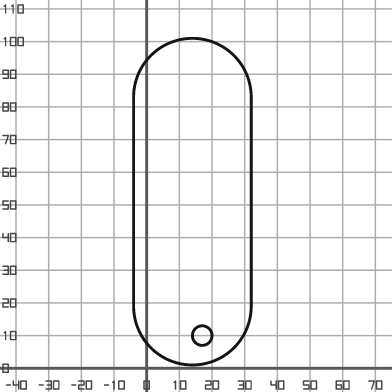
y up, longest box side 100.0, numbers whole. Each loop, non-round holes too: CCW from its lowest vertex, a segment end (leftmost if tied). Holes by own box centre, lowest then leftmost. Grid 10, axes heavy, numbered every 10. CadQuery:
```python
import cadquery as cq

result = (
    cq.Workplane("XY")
    .moveTo(-4.0, 19.0)
    .threePointArc((14.0, 1.0), (32.0, 19.0))
    .lineTo(32.0, 83.0)
    .threePointArc((14.0, 101.0), (-4.0, 83.0))
    .close()
    .moveTo(17.0, 10.0)
    .circle(3.0)
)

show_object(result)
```